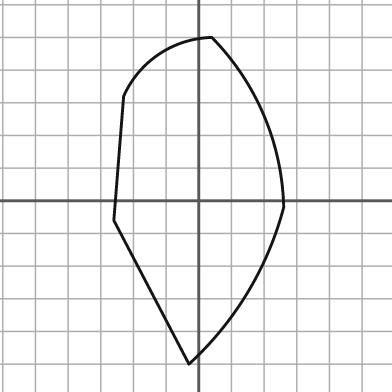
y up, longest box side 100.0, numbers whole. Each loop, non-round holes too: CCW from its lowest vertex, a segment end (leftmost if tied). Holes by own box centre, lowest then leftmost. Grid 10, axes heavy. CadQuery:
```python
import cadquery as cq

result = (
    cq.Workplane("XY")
    .moveTo(-3.0, -50.0)
    .threePointArc((15.0, -28.0), (26.0, -2.0))
    .threePointArc((20.0, 26.0), (4.0, 50.0))
    .threePointArc((-12.0, 45.0), (-23.0, 32.0))
    .lineTo(-26.0, -6.0)
    .close()
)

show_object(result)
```